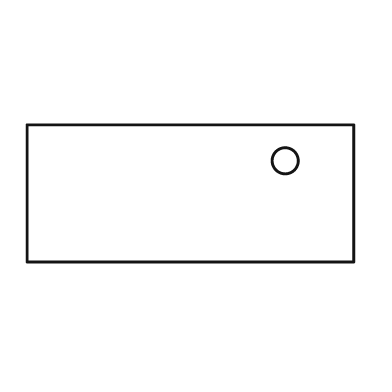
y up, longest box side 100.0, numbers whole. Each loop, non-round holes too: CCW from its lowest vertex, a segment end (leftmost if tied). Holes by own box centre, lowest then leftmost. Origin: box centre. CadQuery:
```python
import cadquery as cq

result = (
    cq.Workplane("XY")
    .moveTo(-50.0, -21.0)
    .lineTo(50.0, -21.0)
    .lineTo(50.0, 21.0)
    .lineTo(-50.0, 21.0)
    .close()
    .moveTo(29.0, 10.0)
    .circle(4.0)
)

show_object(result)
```